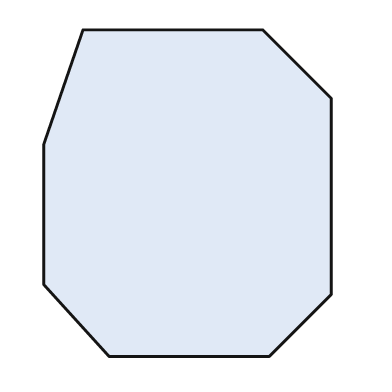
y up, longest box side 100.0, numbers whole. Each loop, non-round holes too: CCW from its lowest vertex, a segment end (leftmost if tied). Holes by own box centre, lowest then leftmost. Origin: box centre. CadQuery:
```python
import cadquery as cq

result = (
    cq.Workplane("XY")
    .moveTo(-24.0, -50.0)
    .lineTo(25.0, -50.0)
    .lineTo(44.0, -31.0)
    .lineTo(44.0, 29.0)
    .lineTo(23.0, 50.0)
    .lineTo(-32.0, 50.0)
    .lineTo(-44.0, 15.0)
    .lineTo(-44.0, -28.0)
    .close()
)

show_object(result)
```